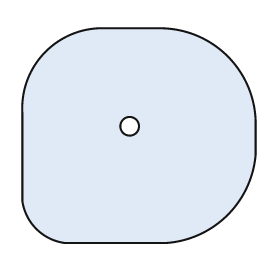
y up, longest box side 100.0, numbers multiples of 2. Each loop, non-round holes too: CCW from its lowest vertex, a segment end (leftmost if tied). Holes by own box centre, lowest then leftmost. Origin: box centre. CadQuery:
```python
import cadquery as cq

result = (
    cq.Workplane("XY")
    .moveTo(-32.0, -46.0)
    .lineTo(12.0, -46.0)
    .threePointArc((38.0, -34.0), (50.0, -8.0))
    .lineTo(50.0, 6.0)
    .threePointArc((38.0, 34.0), (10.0, 46.0))
    .lineTo(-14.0, 46.0)
    .threePointArc((-40.0, 36.0), (-50.0, 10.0))
    .lineTo(-50.0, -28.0)
    .threePointArc((-44.0, -40.0), (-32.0, -46.0))
    .close()
    .moveTo(-4.0, 4.0)
    .circle(4.0)
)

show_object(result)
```